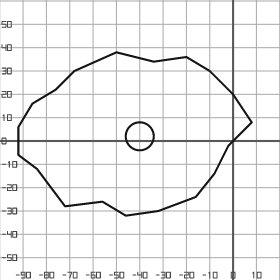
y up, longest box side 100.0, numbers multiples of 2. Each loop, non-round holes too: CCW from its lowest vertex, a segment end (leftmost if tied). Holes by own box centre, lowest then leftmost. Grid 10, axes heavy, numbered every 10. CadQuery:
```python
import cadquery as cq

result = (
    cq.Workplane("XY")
    .moveTo(-46.0, -32.0)
    .lineTo(-32.0, -30.0)
    .lineTo(-16.0, -24.0)
    .lineTo(-8.0, -14.0)
    .lineTo(-2.0, -2.0)
    .lineTo(8.0, 8.0)
    .lineTo(0.0, 20.0)
    .lineTo(-10.0, 30.0)
    .lineTo(-20.0, 36.0)
    .lineTo(-34.0, 34.0)
    .lineTo(-50.0, 38.0)
    .lineTo(-68.0, 30.0)
    .lineTo(-76.0, 22.0)
    .lineTo(-86.0, 16.0)
    .lineTo(-92.0, 6.0)
    .lineTo(-92.0, -6.0)
    .lineTo(-84.0, -12.0)
    .lineTo(-72.0, -28.0)
    .lineTo(-56.0, -26.0)
    .close()
    .moveTo(-40.0, 2.0)
    .circle(6.0)
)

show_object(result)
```